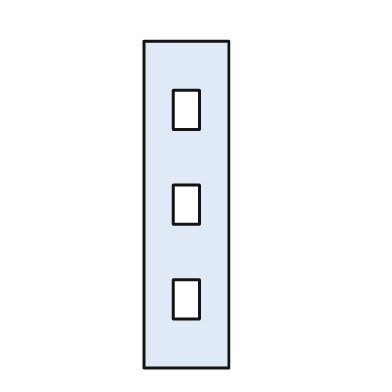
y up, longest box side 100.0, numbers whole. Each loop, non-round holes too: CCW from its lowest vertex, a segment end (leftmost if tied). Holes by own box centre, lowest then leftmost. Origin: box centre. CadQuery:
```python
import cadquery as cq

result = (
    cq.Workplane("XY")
    .moveTo(-13.0, -50.0)
    .lineTo(13.0, -50.0)
    .lineTo(13.0, 50.0)
    .lineTo(-13.0, 50.0)
    .close()
    .moveTo(-4.0, -35.0)
    .lineTo(4.0, -35.0)
    .lineTo(4.0, -23.0)
    .lineTo(-4.0, -23.0)
    .close()
    .moveTo(-4.0, -6.0)
    .lineTo(4.0, -6.0)
    .lineTo(4.0, 6.0)
    .lineTo(-4.0, 6.0)
    .close()
    .moveTo(-4.0, 23.0)
    .lineTo(4.0, 23.0)
    .lineTo(4.0, 35.0)
    .lineTo(-4.0, 35.0)
    .close()
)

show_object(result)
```